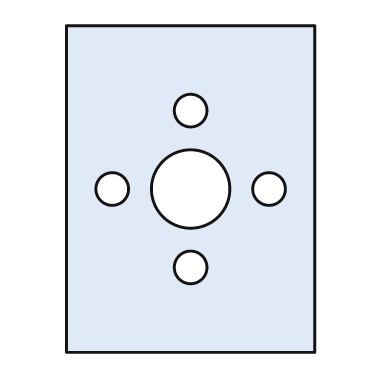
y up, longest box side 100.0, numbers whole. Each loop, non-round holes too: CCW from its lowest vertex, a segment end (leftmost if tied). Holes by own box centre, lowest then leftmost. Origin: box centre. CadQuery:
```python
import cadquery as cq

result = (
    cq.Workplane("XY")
    .moveTo(-38.0, -50.0)
    .lineTo(38.0, -50.0)
    .lineTo(38.0, 50.0)
    .lineTo(-38.0, 50.0)
    .close()
    .moveTo(0.0, -24.0)
    .circle(5.0)
    .moveTo(-24.0, 0.0)
    .circle(5.0)
    .moveTo(0.0, 0.0)
    .circle(12.0)
    .moveTo(24.0, 0.0)
    .circle(5.0)
    .moveTo(0.0, 24.0)
    .circle(5.0)
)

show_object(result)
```